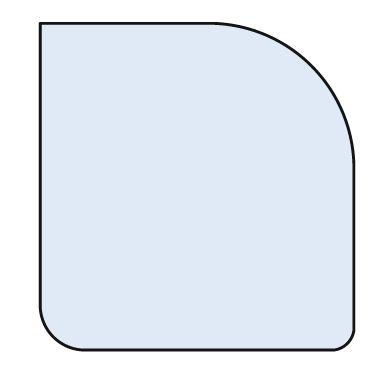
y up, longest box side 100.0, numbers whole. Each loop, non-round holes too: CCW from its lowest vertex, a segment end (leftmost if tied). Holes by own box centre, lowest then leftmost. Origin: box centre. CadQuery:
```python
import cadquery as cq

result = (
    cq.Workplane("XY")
    .moveTo(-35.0, -50.0)
    .lineTo(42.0, -50.0)
    .threePointArc((46.0, -48.0), (48.0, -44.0))
    .lineTo(48.0, 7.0)
    .threePointArc((35.0, 37.0), (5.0, 50.0))
    .lineTo(-48.0, 50.0)
    .lineTo(-48.0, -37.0)
    .threePointArc((-44.0, -46.0), (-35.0, -50.0))
    .close()
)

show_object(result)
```